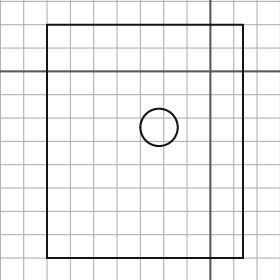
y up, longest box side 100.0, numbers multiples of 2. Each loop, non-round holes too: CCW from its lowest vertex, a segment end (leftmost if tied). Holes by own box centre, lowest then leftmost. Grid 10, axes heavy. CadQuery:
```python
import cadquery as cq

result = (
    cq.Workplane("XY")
    .moveTo(-70.0, -80.0)
    .lineTo(14.0, -80.0)
    .lineTo(14.0, 20.0)
    .lineTo(-70.0, 20.0)
    .close()
    .moveTo(-22.0, -24.0)
    .circle(8.0)
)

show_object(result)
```